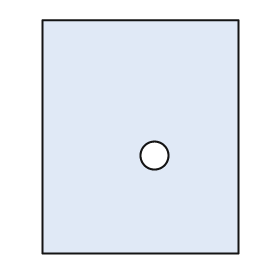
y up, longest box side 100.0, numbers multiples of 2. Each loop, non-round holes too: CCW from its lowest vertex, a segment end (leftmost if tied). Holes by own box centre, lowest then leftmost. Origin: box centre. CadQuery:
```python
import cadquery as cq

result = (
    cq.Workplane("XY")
    .moveTo(-42.0, -50.0)
    .lineTo(42.0, -50.0)
    .lineTo(42.0, 50.0)
    .lineTo(-42.0, 50.0)
    .close()
    .moveTo(6.0, -8.0)
    .circle(6.0)
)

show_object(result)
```